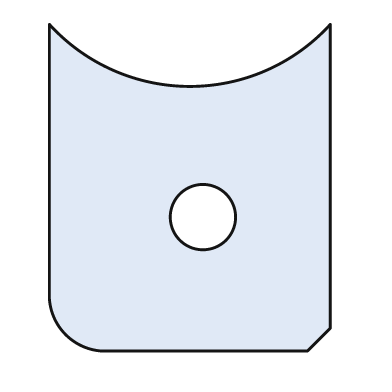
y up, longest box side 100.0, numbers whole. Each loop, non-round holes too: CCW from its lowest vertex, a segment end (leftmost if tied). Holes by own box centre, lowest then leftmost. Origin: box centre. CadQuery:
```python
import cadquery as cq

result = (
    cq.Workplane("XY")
    .moveTo(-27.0, -50.0)
    .lineTo(36.0, -50.0)
    .lineTo(43.0, -43.0)
    .lineTo(43.0, 50.0)
    .threePointArc((0.0, 31.0), (-43.0, 50.0))
    .lineTo(-43.0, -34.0)
    .threePointArc((-38.0, -45.0), (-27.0, -50.0))
    .close()
    .moveTo(4.0, -9.0)
    .circle(10.0)
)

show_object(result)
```